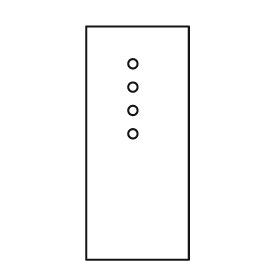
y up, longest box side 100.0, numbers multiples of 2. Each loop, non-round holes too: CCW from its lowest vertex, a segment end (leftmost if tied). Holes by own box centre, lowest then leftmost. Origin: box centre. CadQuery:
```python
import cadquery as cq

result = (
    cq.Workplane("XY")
    .moveTo(-22.0, -50.0)
    .lineTo(22.0, -50.0)
    .lineTo(22.0, 50.0)
    .lineTo(-22.0, 50.0)
    .close()
    .moveTo(-2.0, 4.0)
    .circle(2.0)
    .moveTo(-2.0, 14.0)
    .circle(2.0)
    .moveTo(-2.0, 24.0)
    .circle(2.0)
    .moveTo(-2.0, 34.0)
    .circle(2.0)
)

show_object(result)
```